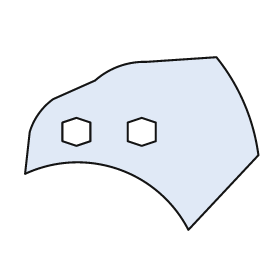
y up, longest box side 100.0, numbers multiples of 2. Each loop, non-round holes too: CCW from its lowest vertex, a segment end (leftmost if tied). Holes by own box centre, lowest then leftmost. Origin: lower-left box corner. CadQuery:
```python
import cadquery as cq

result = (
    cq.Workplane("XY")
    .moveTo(70.0, 0.0)
    .lineTo(100.0, 32.0)
    .threePointArc((94.0, 54.0), (82.0, 74.0))
    .lineTo(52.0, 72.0)
    .threePointArc((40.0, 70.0), (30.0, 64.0))
    .lineTo(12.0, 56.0)
    .threePointArc((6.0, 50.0), (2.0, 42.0))
    .lineTo(0.0, 24.0)
    .threePointArc((40.0, 26.0), (70.0, 0.0))
    .close()
    .moveTo(22.0, 36.0)
    .lineTo(28.0, 38.0)
    .lineTo(28.0, 46.0)
    .lineTo(22.0, 48.0)
    .lineTo(16.0, 46.0)
    .lineTo(16.0, 38.0)
    .close()
    .moveTo(50.0, 36.0)
    .lineTo(56.0, 38.0)
    .lineTo(56.0, 46.0)
    .lineTo(50.0, 48.0)
    .lineTo(44.0, 46.0)
    .lineTo(44.0, 38.0)
    .close()
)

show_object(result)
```